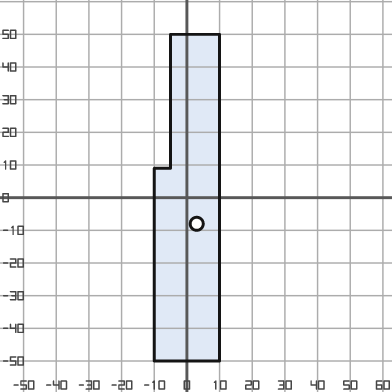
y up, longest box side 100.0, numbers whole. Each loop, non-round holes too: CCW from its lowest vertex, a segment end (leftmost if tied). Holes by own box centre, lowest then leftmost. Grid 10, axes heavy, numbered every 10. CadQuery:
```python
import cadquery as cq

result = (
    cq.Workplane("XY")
    .moveTo(-10.0, -50.0)
    .lineTo(10.0, -50.0)
    .lineTo(10.0, 50.0)
    .lineTo(-5.0, 50.0)
    .lineTo(-5.0, 9.0)
    .lineTo(-10.0, 9.0)
    .close()
    .moveTo(3.0, -8.0)
    .circle(2.0)
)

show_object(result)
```